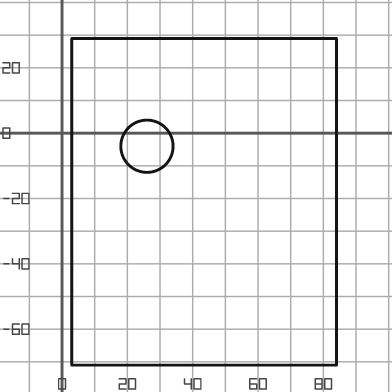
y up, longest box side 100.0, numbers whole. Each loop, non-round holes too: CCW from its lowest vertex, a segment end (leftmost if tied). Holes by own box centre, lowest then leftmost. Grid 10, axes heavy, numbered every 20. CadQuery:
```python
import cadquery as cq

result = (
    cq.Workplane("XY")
    .moveTo(3.0, -71.0)
    .lineTo(84.0, -71.0)
    .lineTo(84.0, 29.0)
    .lineTo(3.0, 29.0)
    .close()
    .moveTo(26.0, -4.0)
    .circle(8.0)
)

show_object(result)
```